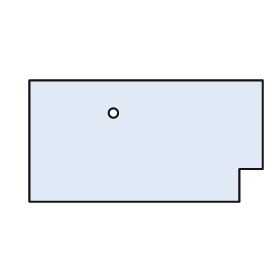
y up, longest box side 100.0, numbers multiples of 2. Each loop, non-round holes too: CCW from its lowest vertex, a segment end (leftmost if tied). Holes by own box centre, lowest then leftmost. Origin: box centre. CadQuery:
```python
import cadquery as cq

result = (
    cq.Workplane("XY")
    .moveTo(-50.0, -26.0)
    .lineTo(40.0, -26.0)
    .lineTo(40.0, -12.0)
    .lineTo(50.0, -12.0)
    .lineTo(50.0, 26.0)
    .lineTo(-50.0, 26.0)
    .close()
    .moveTo(-14.0, 12.0)
    .circle(2.0)
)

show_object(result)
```